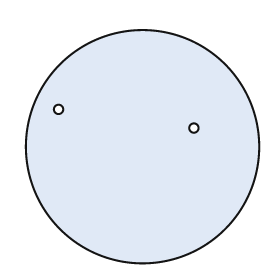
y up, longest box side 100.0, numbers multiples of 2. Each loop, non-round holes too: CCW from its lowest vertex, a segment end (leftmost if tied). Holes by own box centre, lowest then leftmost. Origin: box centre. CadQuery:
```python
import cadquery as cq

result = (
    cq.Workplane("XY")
    .moveTo(0.0, 0.0)
    .circle(50.0)
    .moveTo(22.0, 8.0)
    .circle(2.0)
    .moveTo(-36.0, 16.0)
    .circle(2.0)
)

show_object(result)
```